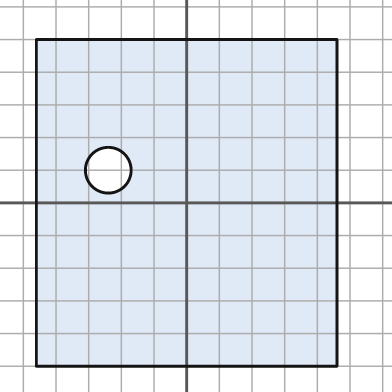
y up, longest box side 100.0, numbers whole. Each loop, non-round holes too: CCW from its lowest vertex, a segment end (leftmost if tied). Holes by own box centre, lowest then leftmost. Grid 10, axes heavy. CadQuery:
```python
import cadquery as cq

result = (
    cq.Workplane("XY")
    .moveTo(-46.0, -50.0)
    .lineTo(46.0, -50.0)
    .lineTo(46.0, 50.0)
    .lineTo(-46.0, 50.0)
    .close()
    .moveTo(-24.0, 10.0)
    .circle(7.0)
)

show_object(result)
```